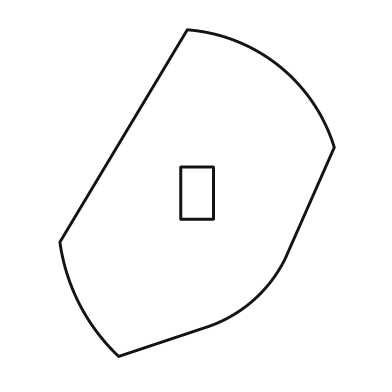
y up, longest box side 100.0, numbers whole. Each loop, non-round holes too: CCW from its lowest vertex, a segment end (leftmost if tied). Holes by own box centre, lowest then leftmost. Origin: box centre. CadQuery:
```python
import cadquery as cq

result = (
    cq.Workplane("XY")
    .moveTo(-24.0, -50.0)
    .lineTo(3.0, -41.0)
    .threePointArc((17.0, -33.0), (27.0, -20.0))
    .lineTo(42.0, 14.0)
    .threePointArc((25.0, 39.0), (-3.0, 50.0))
    .lineTo(-42.0, -15.0)
    .threePointArc((-36.0, -34.0), (-24.0, -50.0))
    .close()
    .moveTo(-5.0, -8.0)
    .lineTo(5.0, -8.0)
    .lineTo(5.0, 8.0)
    .lineTo(-5.0, 8.0)
    .close()
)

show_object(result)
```